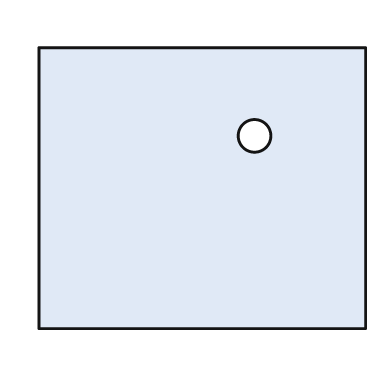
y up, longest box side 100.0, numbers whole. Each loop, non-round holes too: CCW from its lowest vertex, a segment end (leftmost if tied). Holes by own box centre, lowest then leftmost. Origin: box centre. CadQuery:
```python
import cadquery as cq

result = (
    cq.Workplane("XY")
    .moveTo(-50.0, -43.0)
    .lineTo(50.0, -43.0)
    .lineTo(50.0, 43.0)
    .lineTo(-50.0, 43.0)
    .close()
    .moveTo(16.0, 16.0)
    .circle(5.0)
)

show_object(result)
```